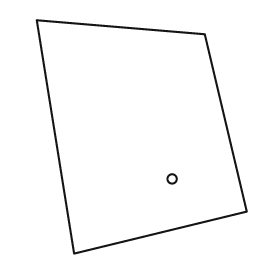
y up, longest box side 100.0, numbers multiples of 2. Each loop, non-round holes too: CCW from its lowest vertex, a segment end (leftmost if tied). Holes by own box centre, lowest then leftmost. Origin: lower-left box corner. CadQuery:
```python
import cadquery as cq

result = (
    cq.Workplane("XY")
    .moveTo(16.0, 0.0)
    .lineTo(90.0, 18.0)
    .lineTo(72.0, 94.0)
    .lineTo(0.0, 100.0)
    .close()
    .moveTo(58.0, 32.0)
    .circle(2.0)
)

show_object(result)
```